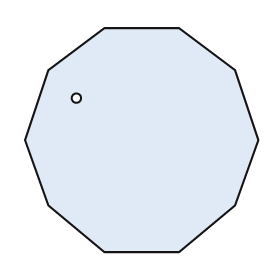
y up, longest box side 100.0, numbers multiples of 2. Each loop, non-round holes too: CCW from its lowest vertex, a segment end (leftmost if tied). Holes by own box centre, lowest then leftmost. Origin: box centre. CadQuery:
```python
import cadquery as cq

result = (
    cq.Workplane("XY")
    .moveTo(-16.0, -48.0)
    .lineTo(16.0, -48.0)
    .lineTo(40.0, -28.0)
    .lineTo(50.0, 0.0)
    .lineTo(40.0, 30.0)
    .lineTo(16.0, 48.0)
    .lineTo(-16.0, 48.0)
    .lineTo(-40.0, 30.0)
    .lineTo(-50.0, 0.0)
    .lineTo(-40.0, -28.0)
    .close()
    .moveTo(-28.0, 18.0)
    .circle(2.0)
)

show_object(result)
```